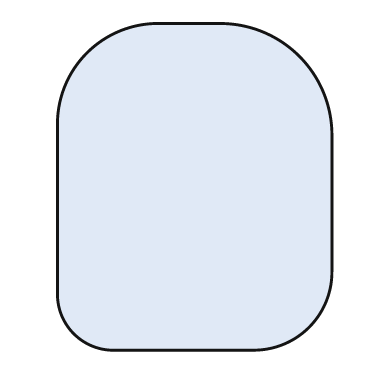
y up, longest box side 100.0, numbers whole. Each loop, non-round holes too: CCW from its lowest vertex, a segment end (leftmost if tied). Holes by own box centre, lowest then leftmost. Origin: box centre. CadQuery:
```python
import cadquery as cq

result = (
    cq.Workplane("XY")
    .moveTo(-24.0, -50.0)
    .lineTo(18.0, -50.0)
    .threePointArc((35.0, -43.0), (42.0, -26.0))
    .lineTo(42.0, 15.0)
    .threePointArc((32.0, 40.0), (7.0, 50.0))
    .lineTo(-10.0, 50.0)
    .threePointArc((-33.0, 41.0), (-42.0, 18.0))
    .lineTo(-42.0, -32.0)
    .threePointArc((-37.0, -45.0), (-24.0, -50.0))
    .close()
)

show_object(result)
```